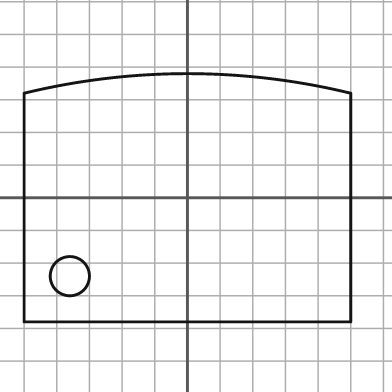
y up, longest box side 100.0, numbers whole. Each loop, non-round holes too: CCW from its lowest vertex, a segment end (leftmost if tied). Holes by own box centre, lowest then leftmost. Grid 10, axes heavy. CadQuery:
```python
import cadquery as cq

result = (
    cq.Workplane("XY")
    .moveTo(-50.0, -38.0)
    .lineTo(50.0, -38.0)
    .lineTo(50.0, 32.0)
    .threePointArc((0.0, 38.0), (-50.0, 32.0))
    .close()
    .moveTo(-36.0, -24.0)
    .circle(6.0)
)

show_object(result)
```